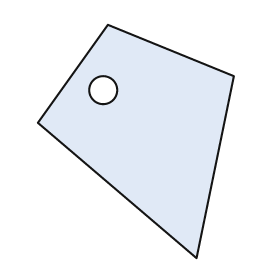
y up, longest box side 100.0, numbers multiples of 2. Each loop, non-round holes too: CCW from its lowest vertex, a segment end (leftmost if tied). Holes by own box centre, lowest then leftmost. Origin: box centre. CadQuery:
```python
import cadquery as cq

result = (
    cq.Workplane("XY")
    .moveTo(26.0, -50.0)
    .lineTo(42.0, 28.0)
    .lineTo(-12.0, 50.0)
    .lineTo(-42.0, 8.0)
    .close()
    .moveTo(-14.0, 22.0)
    .circle(6.0)
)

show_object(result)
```